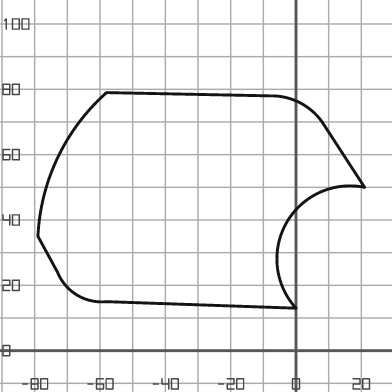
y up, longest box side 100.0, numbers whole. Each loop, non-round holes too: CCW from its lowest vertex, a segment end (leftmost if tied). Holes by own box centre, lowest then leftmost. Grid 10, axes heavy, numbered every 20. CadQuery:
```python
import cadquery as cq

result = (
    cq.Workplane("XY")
    .moveTo(0.0, 13.0)
    .threePointArc((-3.0, 39.0), (21.0, 50.0))
    .lineTo(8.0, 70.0)
    .threePointArc((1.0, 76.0), (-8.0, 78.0))
    .lineTo(-58.0, 79.0)
    .threePointArc((-73.0, 59.0), (-79.0, 35.0))
    .lineTo(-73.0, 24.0)
    .threePointArc((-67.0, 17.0), (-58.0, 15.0))
    .close()
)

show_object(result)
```